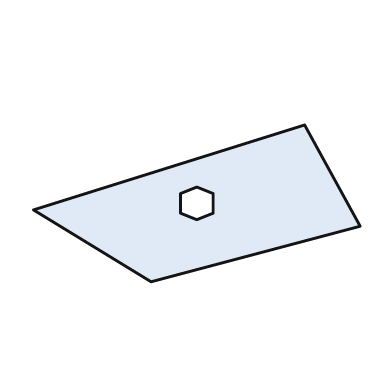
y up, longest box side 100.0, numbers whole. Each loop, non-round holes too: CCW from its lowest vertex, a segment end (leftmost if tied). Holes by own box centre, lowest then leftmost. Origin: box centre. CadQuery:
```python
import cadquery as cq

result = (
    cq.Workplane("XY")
    .moveTo(-14.0, -24.0)
    .lineTo(50.0, -7.0)
    .lineTo(33.0, 24.0)
    .lineTo(-50.0, -2.0)
    .close()
    .moveTo(0.0, -5.0)
    .lineTo(5.0, -3.0)
    .lineTo(5.0, 3.0)
    .lineTo(0.0, 5.0)
    .lineTo(-5.0, 3.0)
    .lineTo(-5.0, -3.0)
    .close()
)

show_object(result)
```